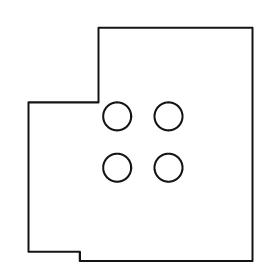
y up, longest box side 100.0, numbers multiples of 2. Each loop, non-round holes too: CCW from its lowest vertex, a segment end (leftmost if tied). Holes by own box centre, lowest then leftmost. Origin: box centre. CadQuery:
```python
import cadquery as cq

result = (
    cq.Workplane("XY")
    .moveTo(-26.0, -50.0)
    .lineTo(48.0, -50.0)
    .lineTo(48.0, 50.0)
    .lineTo(-18.0, 50.0)
    .lineTo(-18.0, 18.0)
    .lineTo(-48.0, 18.0)
    .lineTo(-48.0, -46.0)
    .lineTo(-26.0, -46.0)
    .close()
    .moveTo(-10.0, -10.0)
    .circle(6.0)
    .moveTo(12.0, -10.0)
    .circle(6.0)
    .moveTo(-10.0, 12.0)
    .circle(6.0)
    .moveTo(12.0, 12.0)
    .circle(6.0)
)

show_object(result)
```